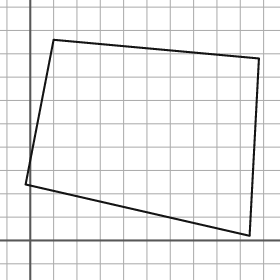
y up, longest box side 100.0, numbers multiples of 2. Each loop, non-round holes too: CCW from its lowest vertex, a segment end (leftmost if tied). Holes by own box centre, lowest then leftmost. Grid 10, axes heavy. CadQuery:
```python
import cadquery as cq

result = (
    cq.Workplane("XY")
    .moveTo(94.0, 2.0)
    .lineTo(98.0, 78.0)
    .lineTo(10.0, 86.0)
    .lineTo(-2.0, 24.0)
    .close()
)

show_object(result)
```